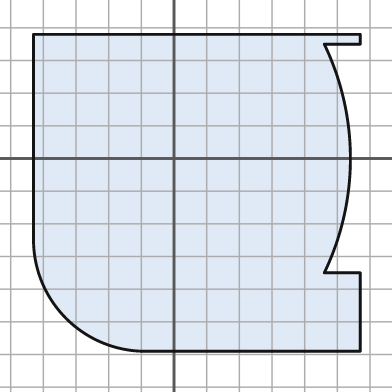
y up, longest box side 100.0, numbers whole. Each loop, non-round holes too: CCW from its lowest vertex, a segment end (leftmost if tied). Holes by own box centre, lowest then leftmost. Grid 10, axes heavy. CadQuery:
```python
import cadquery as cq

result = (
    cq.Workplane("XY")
    .moveTo(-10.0, -59.0)
    .lineTo(57.0, -59.0)
    .lineTo(57.0, -35.0)
    .lineTo(46.0, -35.0)
    .threePointArc((54.0, 0.0), (46.0, 35.0))
    .lineTo(57.0, 35.0)
    .lineTo(57.0, 38.0)
    .lineTo(-43.0, 38.0)
    .lineTo(-43.0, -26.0)
    .threePointArc((-33.0, -49.0), (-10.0, -59.0))
    .close()
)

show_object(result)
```